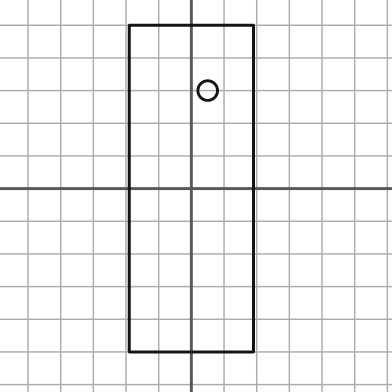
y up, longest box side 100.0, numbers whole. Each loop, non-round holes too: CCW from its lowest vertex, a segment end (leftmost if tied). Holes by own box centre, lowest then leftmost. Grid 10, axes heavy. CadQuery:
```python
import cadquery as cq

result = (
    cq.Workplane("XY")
    .moveTo(-19.0, -50.0)
    .lineTo(19.0, -50.0)
    .lineTo(19.0, 50.0)
    .lineTo(-19.0, 50.0)
    .close()
    .moveTo(5.0, 30.0)
    .circle(3.0)
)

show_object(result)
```